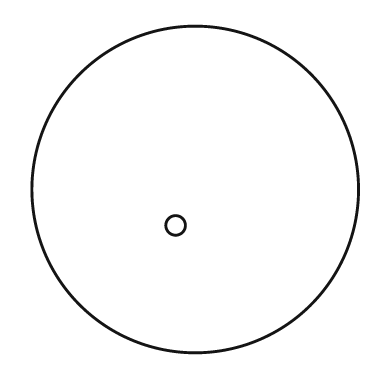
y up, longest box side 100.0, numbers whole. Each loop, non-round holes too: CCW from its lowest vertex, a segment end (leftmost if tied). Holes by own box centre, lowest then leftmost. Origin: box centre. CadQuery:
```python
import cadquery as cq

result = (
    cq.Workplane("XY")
    .moveTo(0.0, 0.0)
    .circle(50.0)
    .moveTo(-6.0, -11.0)
    .circle(3.0)
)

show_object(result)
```